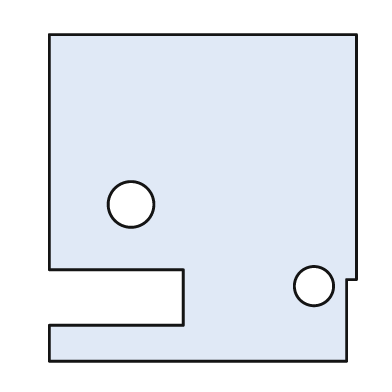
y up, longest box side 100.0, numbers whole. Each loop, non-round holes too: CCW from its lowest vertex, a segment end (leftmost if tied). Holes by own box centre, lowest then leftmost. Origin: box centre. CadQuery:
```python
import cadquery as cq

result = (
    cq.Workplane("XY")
    .moveTo(-47.0, -50.0)
    .lineTo(44.0, -50.0)
    .lineTo(44.0, -25.0)
    .lineTo(47.0, -25.0)
    .lineTo(47.0, 50.0)
    .lineTo(-47.0, 50.0)
    .lineTo(-47.0, -22.0)
    .lineTo(-6.0, -22.0)
    .lineTo(-6.0, -39.0)
    .lineTo(-47.0, -39.0)
    .close()
    .moveTo(34.0, -27.0)
    .circle(6.0)
    .moveTo(-22.0, -2.0)
    .circle(7.0)
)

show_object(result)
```